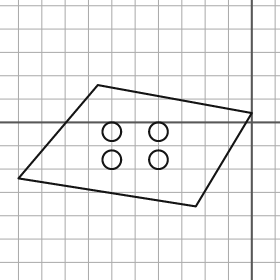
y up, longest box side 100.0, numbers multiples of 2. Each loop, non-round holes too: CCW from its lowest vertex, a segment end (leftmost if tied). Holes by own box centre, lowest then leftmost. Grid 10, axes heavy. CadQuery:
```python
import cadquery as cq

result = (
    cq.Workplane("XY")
    .moveTo(-24.0, -36.0)
    .lineTo(0.0, 4.0)
    .lineTo(-66.0, 16.0)
    .lineTo(-100.0, -24.0)
    .close()
    .moveTo(-60.0, -16.0)
    .circle(4.0)
    .moveTo(-40.0, -16.0)
    .circle(4.0)
    .moveTo(-60.0, -4.0)
    .circle(4.0)
    .moveTo(-40.0, -4.0)
    .circle(4.0)
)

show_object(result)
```